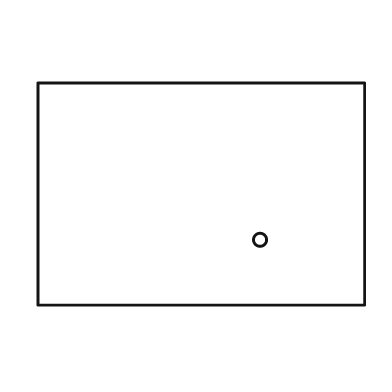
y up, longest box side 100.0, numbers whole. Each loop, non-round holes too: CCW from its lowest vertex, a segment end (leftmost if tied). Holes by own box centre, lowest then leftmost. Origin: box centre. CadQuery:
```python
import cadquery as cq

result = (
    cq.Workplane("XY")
    .moveTo(-50.0, -34.0)
    .lineTo(50.0, -34.0)
    .lineTo(50.0, 34.0)
    .lineTo(-50.0, 34.0)
    .close()
    .moveTo(18.0, -14.0)
    .circle(2.0)
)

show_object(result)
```